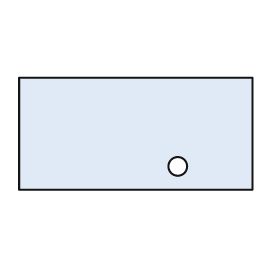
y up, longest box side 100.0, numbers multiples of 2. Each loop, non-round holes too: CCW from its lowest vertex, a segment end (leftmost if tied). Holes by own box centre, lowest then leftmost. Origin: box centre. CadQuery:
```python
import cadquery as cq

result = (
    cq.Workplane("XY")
    .moveTo(-50.0, -24.0)
    .lineTo(50.0, -24.0)
    .lineTo(50.0, 24.0)
    .lineTo(-50.0, 24.0)
    .close()
    .moveTo(18.0, -14.0)
    .circle(4.0)
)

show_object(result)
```